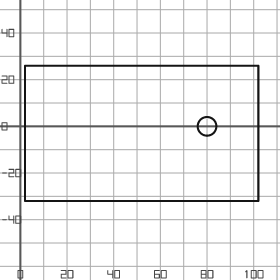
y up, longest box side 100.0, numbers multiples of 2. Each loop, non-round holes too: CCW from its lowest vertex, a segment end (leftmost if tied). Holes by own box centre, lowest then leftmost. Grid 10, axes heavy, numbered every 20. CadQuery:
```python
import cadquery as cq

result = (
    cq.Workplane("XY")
    .moveTo(2.0, -32.0)
    .lineTo(102.0, -32.0)
    .lineTo(102.0, 26.0)
    .lineTo(2.0, 26.0)
    .close()
    .moveTo(80.0, 0.0)
    .circle(4.0)
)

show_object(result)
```